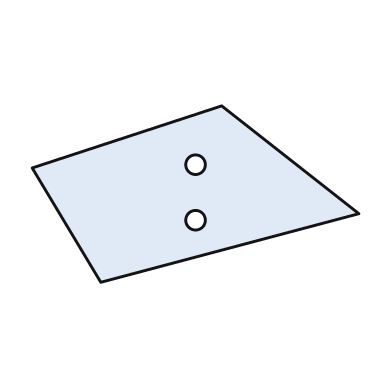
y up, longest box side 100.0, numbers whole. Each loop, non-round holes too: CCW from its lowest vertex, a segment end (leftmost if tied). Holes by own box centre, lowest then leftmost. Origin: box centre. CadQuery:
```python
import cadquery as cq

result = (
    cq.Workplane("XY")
    .moveTo(-29.0, -27.0)
    .lineTo(50.0, -6.0)
    .lineTo(8.0, 27.0)
    .lineTo(-50.0, 8.0)
    .close()
    .moveTo(0.0, -8.0)
    .circle(3.0)
    .moveTo(0.0, 9.0)
    .circle(3.0)
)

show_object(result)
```